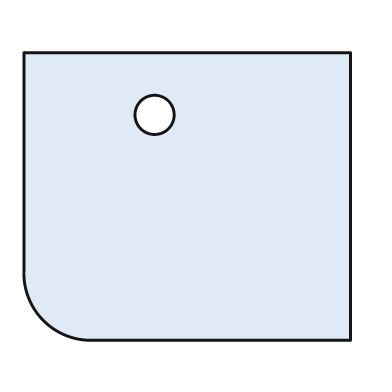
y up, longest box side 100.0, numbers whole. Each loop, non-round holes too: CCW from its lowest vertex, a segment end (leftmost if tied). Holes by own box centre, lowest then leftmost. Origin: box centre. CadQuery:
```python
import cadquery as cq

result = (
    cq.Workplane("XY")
    .moveTo(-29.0, -44.0)
    .lineTo(50.0, -44.0)
    .lineTo(50.0, 44.0)
    .lineTo(-50.0, 44.0)
    .lineTo(-50.0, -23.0)
    .threePointArc((-44.0, -38.0), (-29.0, -44.0))
    .close()
    .moveTo(-10.0, 25.0)
    .circle(6.0)
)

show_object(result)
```